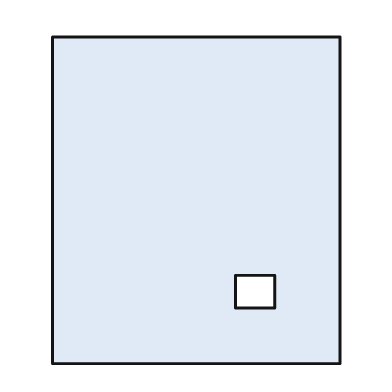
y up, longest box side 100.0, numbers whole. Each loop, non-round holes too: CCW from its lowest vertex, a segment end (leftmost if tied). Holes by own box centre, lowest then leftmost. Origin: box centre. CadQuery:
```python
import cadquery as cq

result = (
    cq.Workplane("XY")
    .moveTo(-44.0, -50.0)
    .lineTo(44.0, -50.0)
    .lineTo(44.0, 50.0)
    .lineTo(-44.0, 50.0)
    .close()
    .moveTo(12.0, -33.0)
    .lineTo(24.0, -33.0)
    .lineTo(24.0, -23.0)
    .lineTo(12.0, -23.0)
    .close()
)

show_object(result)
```